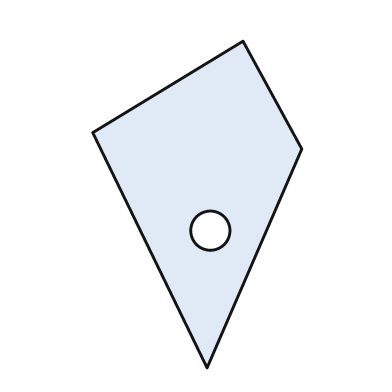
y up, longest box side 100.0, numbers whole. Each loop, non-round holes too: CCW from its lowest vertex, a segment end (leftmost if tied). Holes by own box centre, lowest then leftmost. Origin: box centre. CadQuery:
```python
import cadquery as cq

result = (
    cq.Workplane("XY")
    .moveTo(3.0, -50.0)
    .lineTo(32.0, 17.0)
    .lineTo(14.0, 50.0)
    .lineTo(-32.0, 22.0)
    .close()
    .moveTo(4.0, -8.0)
    .circle(6.0)
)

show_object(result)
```